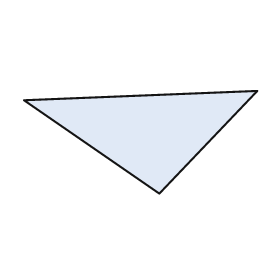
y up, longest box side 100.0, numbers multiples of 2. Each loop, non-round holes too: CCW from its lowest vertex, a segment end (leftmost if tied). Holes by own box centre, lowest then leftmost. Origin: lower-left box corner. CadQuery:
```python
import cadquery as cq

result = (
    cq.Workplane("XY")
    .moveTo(58.0, 0.0)
    .lineTo(100.0, 44.0)
    .lineTo(0.0, 40.0)
    .close()
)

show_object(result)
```